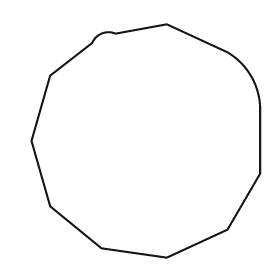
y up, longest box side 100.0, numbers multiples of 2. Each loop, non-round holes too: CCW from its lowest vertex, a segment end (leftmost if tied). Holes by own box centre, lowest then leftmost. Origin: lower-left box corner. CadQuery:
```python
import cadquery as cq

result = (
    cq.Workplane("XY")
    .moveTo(58.0, 0.0)
    .lineTo(84.0, 12.0)
    .lineTo(98.0, 36.0)
    .lineTo(98.0, 64.0)
    .threePointArc((94.0, 78.0), (84.0, 88.0))
    .lineTo(58.0, 100.0)
    .lineTo(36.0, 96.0)
    .threePointArc((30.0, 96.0), (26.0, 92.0))
    .lineTo(8.0, 78.0)
    .lineTo(0.0, 50.0)
    .lineTo(8.0, 22.0)
    .lineTo(30.0, 4.0)
    .close()
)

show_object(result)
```